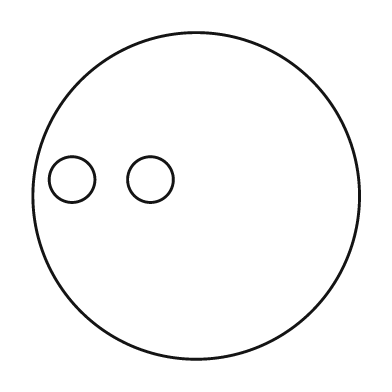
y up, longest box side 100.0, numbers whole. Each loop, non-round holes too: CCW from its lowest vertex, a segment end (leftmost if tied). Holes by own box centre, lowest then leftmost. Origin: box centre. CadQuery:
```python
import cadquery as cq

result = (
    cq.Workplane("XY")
    .moveTo(0.0, 0.0)
    .circle(50.0)
    .moveTo(-38.0, 5.0)
    .circle(7.0)
    .moveTo(-14.0, 5.0)
    .circle(7.0)
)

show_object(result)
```